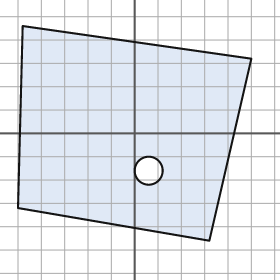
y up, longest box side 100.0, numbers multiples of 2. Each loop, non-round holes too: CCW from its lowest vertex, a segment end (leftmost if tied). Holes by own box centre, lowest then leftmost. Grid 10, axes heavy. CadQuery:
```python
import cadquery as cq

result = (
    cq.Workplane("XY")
    .moveTo(32.0, -46.0)
    .lineTo(50.0, 32.0)
    .lineTo(-48.0, 46.0)
    .lineTo(-50.0, -32.0)
    .close()
    .moveTo(6.0, -16.0)
    .circle(6.0)
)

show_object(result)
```